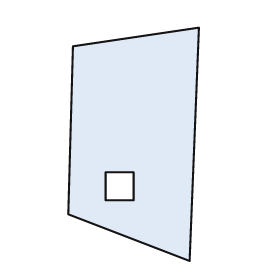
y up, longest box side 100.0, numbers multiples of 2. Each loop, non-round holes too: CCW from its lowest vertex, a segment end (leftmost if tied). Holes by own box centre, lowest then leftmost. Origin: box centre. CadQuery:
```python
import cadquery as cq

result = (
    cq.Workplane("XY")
    .moveTo(24.0, -50.0)
    .lineTo(28.0, 50.0)
    .lineTo(-26.0, 42.0)
    .lineTo(-28.0, -30.0)
    .close()
    .moveTo(-12.0, -24.0)
    .lineTo(0.0, -24.0)
    .lineTo(0.0, -12.0)
    .lineTo(-12.0, -12.0)
    .close()
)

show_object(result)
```